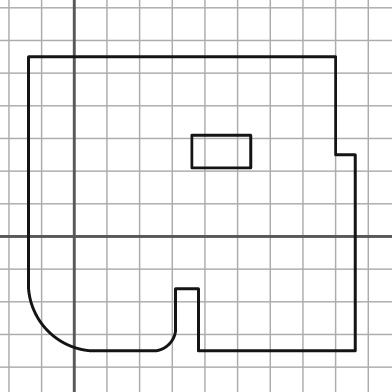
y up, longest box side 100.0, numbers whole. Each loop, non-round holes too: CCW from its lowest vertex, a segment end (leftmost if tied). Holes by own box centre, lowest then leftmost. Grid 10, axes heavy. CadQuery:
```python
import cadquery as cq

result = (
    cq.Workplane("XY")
    .moveTo(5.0, -35.0)
    .lineTo(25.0, -35.0)
    .threePointArc((29.0, -33.0), (31.0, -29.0))
    .lineTo(31.0, -16.0)
    .lineTo(38.0, -16.0)
    .lineTo(38.0, -35.0)
    .lineTo(86.0, -35.0)
    .lineTo(86.0, 25.0)
    .lineTo(80.0, 25.0)
    .lineTo(80.0, 55.0)
    .lineTo(-14.0, 55.0)
    .lineTo(-14.0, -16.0)
    .threePointArc((-8.0, -29.0), (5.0, -35.0))
    .close()
    .moveTo(36.0, 21.0)
    .lineTo(54.0, 21.0)
    .lineTo(54.0, 31.0)
    .lineTo(36.0, 31.0)
    .close()
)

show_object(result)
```